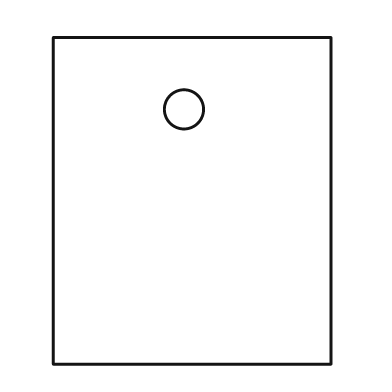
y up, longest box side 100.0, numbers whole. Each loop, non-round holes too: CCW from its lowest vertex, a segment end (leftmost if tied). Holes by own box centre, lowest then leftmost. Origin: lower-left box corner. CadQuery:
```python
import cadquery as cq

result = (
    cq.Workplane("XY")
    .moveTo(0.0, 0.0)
    .lineTo(85.0, 0.0)
    .lineTo(85.0, 100.0)
    .lineTo(0.0, 100.0)
    .close()
    .moveTo(40.0, 78.0)
    .circle(6.0)
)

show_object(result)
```